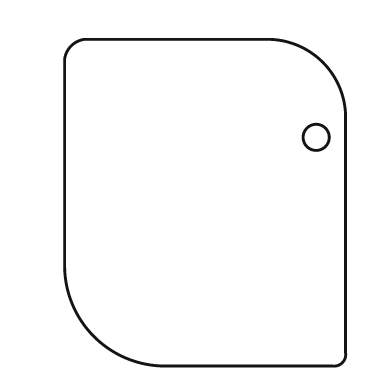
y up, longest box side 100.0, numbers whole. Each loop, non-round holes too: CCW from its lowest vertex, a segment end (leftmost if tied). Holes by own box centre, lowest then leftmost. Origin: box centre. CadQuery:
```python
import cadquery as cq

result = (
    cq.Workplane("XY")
    .moveTo(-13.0, -50.0)
    .lineTo(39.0, -50.0)
    .threePointArc((42.0, -49.0), (43.0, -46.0))
    .lineTo(43.0, 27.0)
    .threePointArc((36.0, 43.0), (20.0, 50.0))
    .lineTo(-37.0, 50.0)
    .threePointArc((-41.0, 48.0), (-43.0, 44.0))
    .lineTo(-43.0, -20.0)
    .threePointArc((-34.0, -41.0), (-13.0, -50.0))
    .close()
    .moveTo(34.0, 20.0)
    .circle(4.0)
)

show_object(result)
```